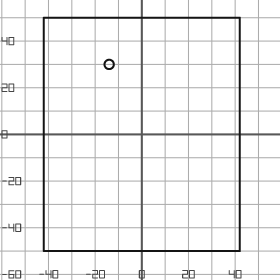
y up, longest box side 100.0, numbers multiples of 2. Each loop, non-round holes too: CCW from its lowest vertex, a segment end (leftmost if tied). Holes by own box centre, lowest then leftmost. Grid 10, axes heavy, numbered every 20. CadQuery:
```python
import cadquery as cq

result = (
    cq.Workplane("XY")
    .moveTo(-42.0, -50.0)
    .lineTo(42.0, -50.0)
    .lineTo(42.0, 50.0)
    .lineTo(-42.0, 50.0)
    .close()
    .moveTo(-14.0, 30.0)
    .circle(2.0)
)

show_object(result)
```